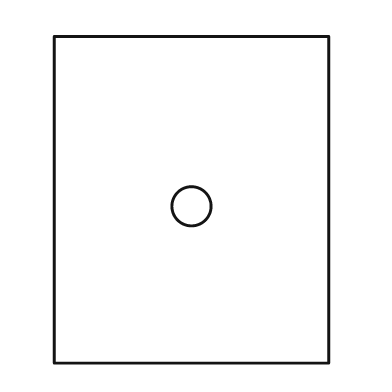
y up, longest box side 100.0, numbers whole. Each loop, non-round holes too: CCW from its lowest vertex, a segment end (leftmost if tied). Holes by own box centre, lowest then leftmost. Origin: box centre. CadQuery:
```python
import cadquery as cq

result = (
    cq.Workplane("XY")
    .moveTo(-42.0, -50.0)
    .lineTo(42.0, -50.0)
    .lineTo(42.0, 50.0)
    .lineTo(-42.0, 50.0)
    .close()
    .moveTo(0.0, -2.0)
    .circle(6.0)
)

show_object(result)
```